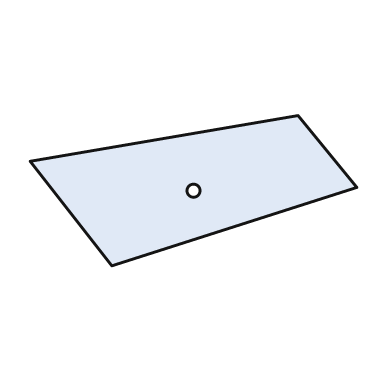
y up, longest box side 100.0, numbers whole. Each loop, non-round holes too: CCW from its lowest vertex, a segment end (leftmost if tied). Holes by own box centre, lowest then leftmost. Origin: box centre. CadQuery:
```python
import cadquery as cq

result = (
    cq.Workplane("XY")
    .moveTo(-25.0, -23.0)
    .lineTo(50.0, 1.0)
    .lineTo(32.0, 23.0)
    .lineTo(-50.0, 9.0)
    .close()
    .moveTo(0.0, 0.0)
    .circle(2.0)
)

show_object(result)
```